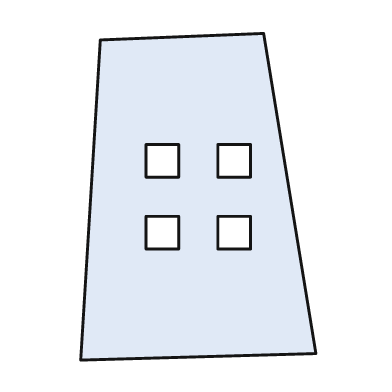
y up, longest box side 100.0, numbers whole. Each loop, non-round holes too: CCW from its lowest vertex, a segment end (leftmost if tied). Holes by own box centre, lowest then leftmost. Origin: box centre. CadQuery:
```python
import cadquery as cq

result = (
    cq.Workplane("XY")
    .moveTo(-36.0, -50.0)
    .lineTo(36.0, -48.0)
    .lineTo(20.0, 50.0)
    .lineTo(-30.0, 48.0)
    .close()
    .moveTo(-16.0, -16.0)
    .lineTo(-6.0, -16.0)
    .lineTo(-6.0, -6.0)
    .lineTo(-16.0, -6.0)
    .close()
    .moveTo(6.0, -16.0)
    .lineTo(16.0, -16.0)
    .lineTo(16.0, -6.0)
    .lineTo(6.0, -6.0)
    .close()
    .moveTo(-16.0, 6.0)
    .lineTo(-6.0, 6.0)
    .lineTo(-6.0, 16.0)
    .lineTo(-16.0, 16.0)
    .close()
    .moveTo(6.0, 6.0)
    .lineTo(16.0, 6.0)
    .lineTo(16.0, 16.0)
    .lineTo(6.0, 16.0)
    .close()
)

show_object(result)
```